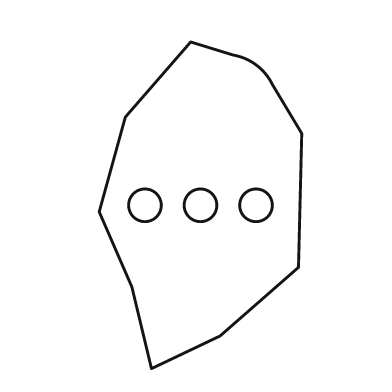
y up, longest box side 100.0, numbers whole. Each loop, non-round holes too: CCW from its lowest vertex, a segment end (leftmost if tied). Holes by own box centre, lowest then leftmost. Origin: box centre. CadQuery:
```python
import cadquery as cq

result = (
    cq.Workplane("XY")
    .moveTo(-15.0, -50.0)
    .lineTo(6.0, -40.0)
    .lineTo(30.0, -19.0)
    .lineTo(31.0, 22.0)
    .lineTo(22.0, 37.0)
    .threePointArc((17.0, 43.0), (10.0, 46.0))
    .lineTo(-3.0, 50.0)
    .lineTo(-23.0, 27.0)
    .lineTo(-31.0, -2.0)
    .lineTo(-21.0, -25.0)
    .close()
    .moveTo(-17.0, 0.0)
    .circle(5.0)
    .moveTo(0.0, 0.0)
    .circle(5.0)
    .moveTo(17.0, 0.0)
    .circle(5.0)
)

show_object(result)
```